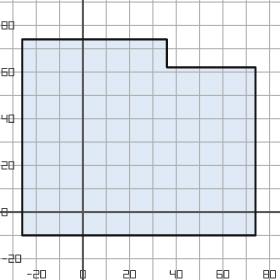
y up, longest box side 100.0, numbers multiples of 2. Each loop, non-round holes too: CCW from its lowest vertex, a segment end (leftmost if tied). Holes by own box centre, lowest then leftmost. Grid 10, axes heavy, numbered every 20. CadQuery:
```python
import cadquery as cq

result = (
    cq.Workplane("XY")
    .moveTo(-26.0, -10.0)
    .lineTo(74.0, -10.0)
    .lineTo(74.0, 62.0)
    .lineTo(36.0, 62.0)
    .lineTo(36.0, 74.0)
    .lineTo(-26.0, 74.0)
    .close()
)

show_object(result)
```